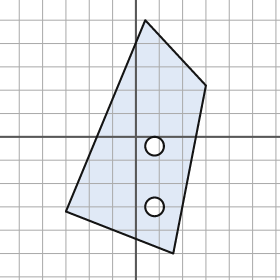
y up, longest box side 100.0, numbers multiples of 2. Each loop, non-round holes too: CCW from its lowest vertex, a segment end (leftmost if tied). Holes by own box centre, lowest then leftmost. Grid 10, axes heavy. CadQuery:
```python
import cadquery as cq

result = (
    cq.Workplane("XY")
    .moveTo(16.0, -50.0)
    .lineTo(30.0, 22.0)
    .lineTo(4.0, 50.0)
    .lineTo(-30.0, -32.0)
    .close()
    .moveTo(8.0, -30.0)
    .circle(4.0)
    .moveTo(8.0, -4.0)
    .circle(4.0)
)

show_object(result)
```